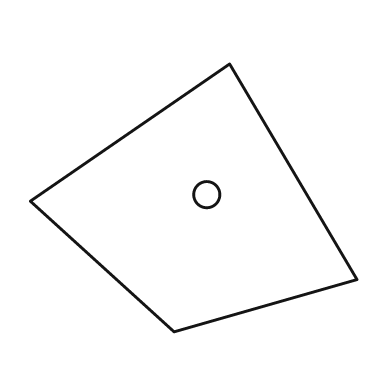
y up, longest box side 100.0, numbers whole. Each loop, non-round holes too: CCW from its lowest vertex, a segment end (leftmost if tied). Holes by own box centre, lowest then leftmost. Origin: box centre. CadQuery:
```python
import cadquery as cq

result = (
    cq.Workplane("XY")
    .moveTo(-6.0, -41.0)
    .lineTo(50.0, -25.0)
    .lineTo(11.0, 41.0)
    .lineTo(-50.0, -1.0)
    .close()
    .moveTo(4.0, 1.0)
    .circle(4.0)
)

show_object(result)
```